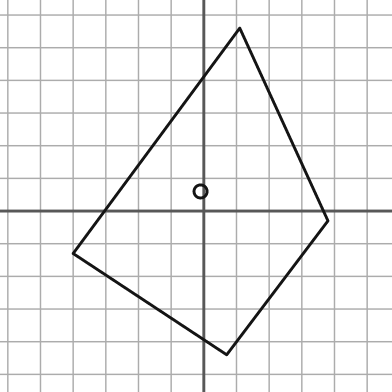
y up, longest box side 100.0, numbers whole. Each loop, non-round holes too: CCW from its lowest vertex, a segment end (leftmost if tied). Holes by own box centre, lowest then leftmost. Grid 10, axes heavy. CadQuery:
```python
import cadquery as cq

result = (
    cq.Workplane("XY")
    .moveTo(7.0, -44.0)
    .lineTo(38.0, -3.0)
    .lineTo(11.0, 56.0)
    .lineTo(-40.0, -13.0)
    .close()
    .moveTo(-1.0, 6.0)
    .circle(2.0)
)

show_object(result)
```